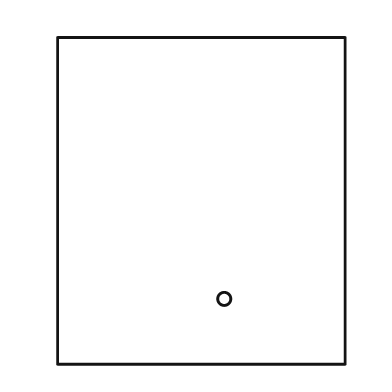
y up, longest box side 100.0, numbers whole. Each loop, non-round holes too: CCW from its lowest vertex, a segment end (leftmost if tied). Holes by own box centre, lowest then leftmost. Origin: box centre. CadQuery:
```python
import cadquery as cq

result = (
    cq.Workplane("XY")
    .moveTo(-44.0, -50.0)
    .lineTo(44.0, -50.0)
    .lineTo(44.0, 50.0)
    .lineTo(-44.0, 50.0)
    .close()
    .moveTo(7.0, -30.0)
    .circle(2.0)
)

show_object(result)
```